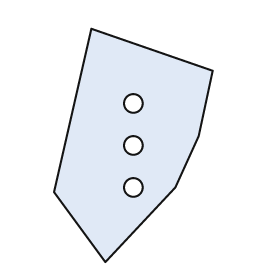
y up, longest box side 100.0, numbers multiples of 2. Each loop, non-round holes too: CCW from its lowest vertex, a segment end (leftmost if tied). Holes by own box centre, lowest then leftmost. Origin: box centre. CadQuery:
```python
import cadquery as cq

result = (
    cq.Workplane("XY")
    .moveTo(-12.0, -50.0)
    .lineTo(18.0, -18.0)
    .lineTo(28.0, 4.0)
    .lineTo(34.0, 32.0)
    .lineTo(-18.0, 50.0)
    .lineTo(-34.0, -20.0)
    .close()
    .moveTo(0.0, -18.0)
    .circle(4.0)
    .moveTo(0.0, 0.0)
    .circle(4.0)
    .moveTo(0.0, 18.0)
    .circle(4.0)
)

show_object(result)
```